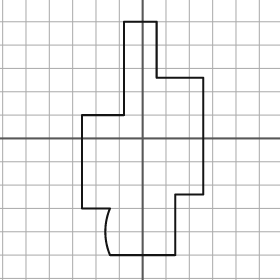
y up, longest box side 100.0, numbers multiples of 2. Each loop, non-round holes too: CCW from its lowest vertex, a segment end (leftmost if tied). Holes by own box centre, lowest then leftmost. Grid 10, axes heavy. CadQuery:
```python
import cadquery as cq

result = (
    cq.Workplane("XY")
    .moveTo(-14.0, -50.0)
    .lineTo(14.0, -50.0)
    .lineTo(14.0, -24.0)
    .lineTo(26.0, -24.0)
    .lineTo(26.0, 26.0)
    .lineTo(6.0, 26.0)
    .lineTo(6.0, 50.0)
    .lineTo(-8.0, 50.0)
    .lineTo(-8.0, 10.0)
    .lineTo(-26.0, 10.0)
    .lineTo(-26.0, -30.0)
    .lineTo(-14.0, -30.0)
    .threePointArc((-16.0, -40.0), (-14.0, -50.0))
    .close()
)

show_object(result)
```